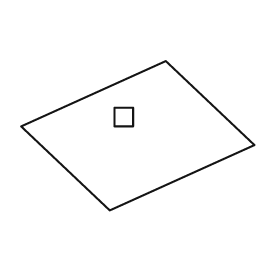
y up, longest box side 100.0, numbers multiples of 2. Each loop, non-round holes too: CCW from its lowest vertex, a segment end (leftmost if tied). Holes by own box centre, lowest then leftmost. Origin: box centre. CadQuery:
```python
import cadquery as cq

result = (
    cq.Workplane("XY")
    .moveTo(-12.0, -32.0)
    .lineTo(50.0, -4.0)
    .lineTo(12.0, 32.0)
    .lineTo(-50.0, 4.0)
    .close()
    .moveTo(-10.0, 4.0)
    .lineTo(-2.0, 4.0)
    .lineTo(-2.0, 12.0)
    .lineTo(-10.0, 12.0)
    .close()
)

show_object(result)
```